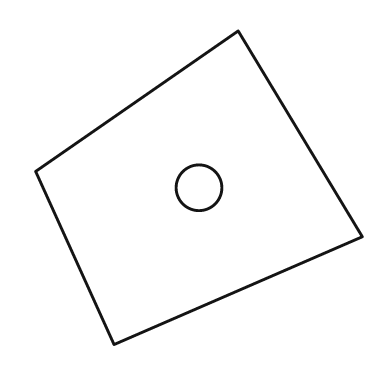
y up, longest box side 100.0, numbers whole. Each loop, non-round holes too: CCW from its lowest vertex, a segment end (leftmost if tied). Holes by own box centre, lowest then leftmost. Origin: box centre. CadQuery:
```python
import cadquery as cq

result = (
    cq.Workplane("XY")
    .moveTo(-26.0, -48.0)
    .lineTo(50.0, -15.0)
    .lineTo(12.0, 48.0)
    .lineTo(-50.0, 5.0)
    .close()
    .moveTo(0.0, 0.0)
    .circle(7.0)
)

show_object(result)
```